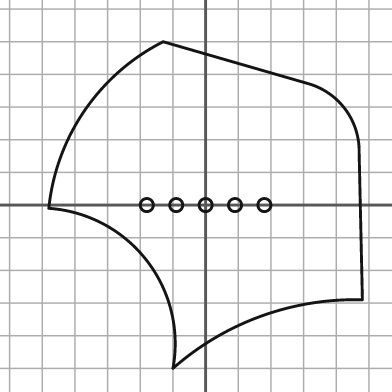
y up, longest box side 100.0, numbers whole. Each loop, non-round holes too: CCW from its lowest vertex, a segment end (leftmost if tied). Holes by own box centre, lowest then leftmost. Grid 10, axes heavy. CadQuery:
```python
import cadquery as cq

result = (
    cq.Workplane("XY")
    .moveTo(-10.0, -50.0)
    .threePointArc((17.0, -34.0), (48.0, -29.0))
    .lineTo(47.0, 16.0)
    .threePointArc((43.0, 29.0), (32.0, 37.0))
    .lineTo(-13.0, 50.0)
    .threePointArc((-37.0, 29.0), (-48.0, -1.0))
    .threePointArc((-18.0, -17.0), (-10.0, -50.0))
    .close()
    .moveTo(-18.0, 0.0)
    .circle(2.0)
    .moveTo(-9.0, 0.0)
    .circle(2.0)
    .moveTo(0.0, 0.0)
    .circle(2.0)
    .moveTo(9.0, 0.0)
    .circle(2.0)
    .moveTo(18.0, 0.0)
    .circle(2.0)
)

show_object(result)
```